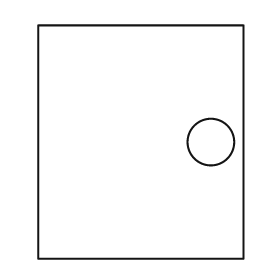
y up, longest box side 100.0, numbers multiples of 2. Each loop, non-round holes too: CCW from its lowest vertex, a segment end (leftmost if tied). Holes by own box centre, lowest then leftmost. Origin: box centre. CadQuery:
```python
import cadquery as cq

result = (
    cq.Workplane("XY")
    .moveTo(-44.0, -50.0)
    .lineTo(44.0, -50.0)
    .lineTo(44.0, 50.0)
    .lineTo(-44.0, 50.0)
    .close()
    .moveTo(30.0, 0.0)
    .circle(10.0)
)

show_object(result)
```